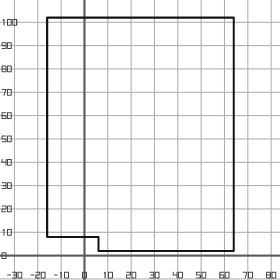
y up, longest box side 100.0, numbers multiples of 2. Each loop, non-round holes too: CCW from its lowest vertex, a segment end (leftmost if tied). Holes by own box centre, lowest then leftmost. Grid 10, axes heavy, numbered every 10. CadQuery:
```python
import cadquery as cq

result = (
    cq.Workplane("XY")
    .moveTo(6.0, 2.0)
    .lineTo(64.0, 2.0)
    .lineTo(64.0, 102.0)
    .lineTo(-16.0, 102.0)
    .lineTo(-16.0, 8.0)
    .lineTo(6.0, 8.0)
    .close()
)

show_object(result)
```